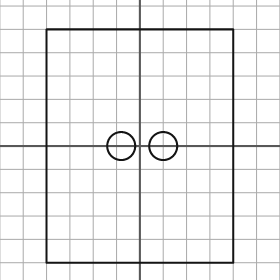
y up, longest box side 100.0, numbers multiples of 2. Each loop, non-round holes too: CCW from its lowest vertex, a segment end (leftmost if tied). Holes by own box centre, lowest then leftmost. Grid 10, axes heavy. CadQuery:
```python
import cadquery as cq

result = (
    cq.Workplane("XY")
    .moveTo(-40.0, -50.0)
    .lineTo(40.0, -50.0)
    .lineTo(40.0, 50.0)
    .lineTo(-40.0, 50.0)
    .close()
    .moveTo(-8.0, 0.0)
    .circle(6.0)
    .moveTo(10.0, 0.0)
    .circle(6.0)
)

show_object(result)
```